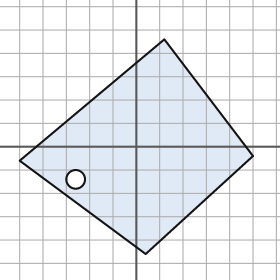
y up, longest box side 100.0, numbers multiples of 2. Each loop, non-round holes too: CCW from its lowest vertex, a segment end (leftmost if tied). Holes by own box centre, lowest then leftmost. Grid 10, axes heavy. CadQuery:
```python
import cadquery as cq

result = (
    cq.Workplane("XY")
    .moveTo(4.0, -46.0)
    .lineTo(50.0, -4.0)
    .lineTo(12.0, 46.0)
    .lineTo(-50.0, -6.0)
    .close()
    .moveTo(-26.0, -14.0)
    .circle(4.0)
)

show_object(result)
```